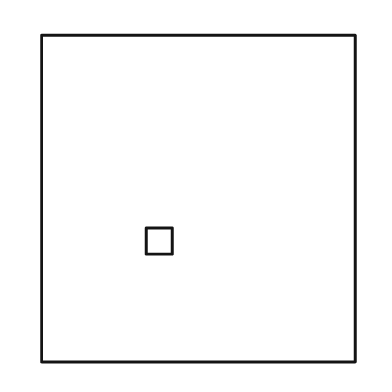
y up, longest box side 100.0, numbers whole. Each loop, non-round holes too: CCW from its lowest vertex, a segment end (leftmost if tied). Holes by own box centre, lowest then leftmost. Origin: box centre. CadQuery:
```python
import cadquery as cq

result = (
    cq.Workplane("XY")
    .moveTo(-48.0, -50.0)
    .lineTo(48.0, -50.0)
    .lineTo(48.0, 50.0)
    .lineTo(-48.0, 50.0)
    .close()
    .moveTo(-16.0, -17.0)
    .lineTo(-8.0, -17.0)
    .lineTo(-8.0, -9.0)
    .lineTo(-16.0, -9.0)
    .close()
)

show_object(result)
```